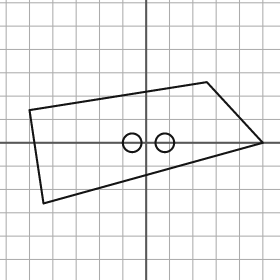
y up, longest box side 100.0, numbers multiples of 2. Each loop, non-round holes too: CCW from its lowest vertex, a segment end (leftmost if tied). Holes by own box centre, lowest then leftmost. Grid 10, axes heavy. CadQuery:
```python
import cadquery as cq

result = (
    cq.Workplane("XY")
    .moveTo(-44.0, -26.0)
    .lineTo(50.0, 0.0)
    .lineTo(26.0, 26.0)
    .lineTo(-50.0, 14.0)
    .close()
    .moveTo(-6.0, 0.0)
    .circle(4.0)
    .moveTo(8.0, 0.0)
    .circle(4.0)
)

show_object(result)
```